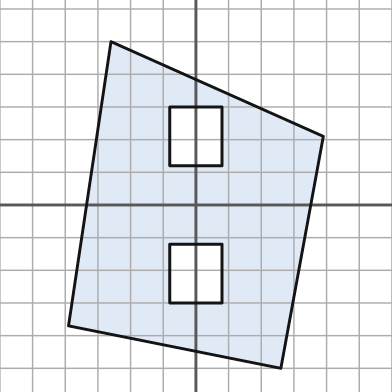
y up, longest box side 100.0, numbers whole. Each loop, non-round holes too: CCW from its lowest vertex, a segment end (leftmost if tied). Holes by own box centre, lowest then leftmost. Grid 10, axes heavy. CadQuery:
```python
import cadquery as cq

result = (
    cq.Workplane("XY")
    .moveTo(26.0, -50.0)
    .lineTo(39.0, 21.0)
    .lineTo(-26.0, 50.0)
    .lineTo(-39.0, -37.0)
    .close()
    .moveTo(-8.0, -30.0)
    .lineTo(8.0, -30.0)
    .lineTo(8.0, -12.0)
    .lineTo(-8.0, -12.0)
    .close()
    .moveTo(-8.0, 12.0)
    .lineTo(8.0, 12.0)
    .lineTo(8.0, 30.0)
    .lineTo(-8.0, 30.0)
    .close()
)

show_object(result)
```